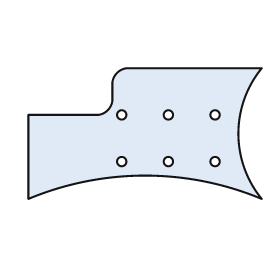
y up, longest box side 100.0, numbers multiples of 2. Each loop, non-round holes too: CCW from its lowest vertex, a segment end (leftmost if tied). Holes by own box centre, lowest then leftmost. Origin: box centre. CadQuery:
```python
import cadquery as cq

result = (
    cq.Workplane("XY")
    .moveTo(-50.0, -28.0)
    .threePointArc((0.0, -18.0), (50.0, -28.0))
    .threePointArc((40.0, 0.0), (50.0, 28.0))
    .lineTo(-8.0, 28.0)
    .threePointArc((-12.0, 26.0), (-14.0, 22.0))
    .lineTo(-14.0, 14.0)
    .threePointArc((-16.0, 10.0), (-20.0, 8.0))
    .lineTo(-50.0, 8.0)
    .close()
    .moveTo(-10.0, -12.0)
    .circle(2.0)
    .moveTo(10.0, -12.0)
    .circle(2.0)
    .moveTo(30.0, -12.0)
    .circle(2.0)
    .moveTo(-10.0, 8.0)
    .circle(2.0)
    .moveTo(10.0, 8.0)
    .circle(2.0)
    .moveTo(30.0, 8.0)
    .circle(2.0)
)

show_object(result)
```